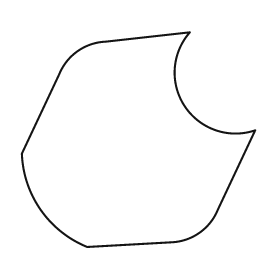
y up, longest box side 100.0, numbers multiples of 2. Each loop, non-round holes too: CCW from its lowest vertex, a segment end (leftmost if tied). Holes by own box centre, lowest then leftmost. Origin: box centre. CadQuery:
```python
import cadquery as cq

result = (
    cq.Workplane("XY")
    .moveTo(-22.0, -46.0)
    .lineTo(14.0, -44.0)
    .threePointArc((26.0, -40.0), (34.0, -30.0))
    .lineTo(50.0, 4.0)
    .threePointArc((20.0, 14.0), (22.0, 46.0))
    .lineTo(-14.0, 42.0)
    .threePointArc((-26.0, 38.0), (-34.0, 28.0))
    .lineTo(-50.0, -6.0)
    .threePointArc((-42.0, -30.0), (-22.0, -46.0))
    .close()
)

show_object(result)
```